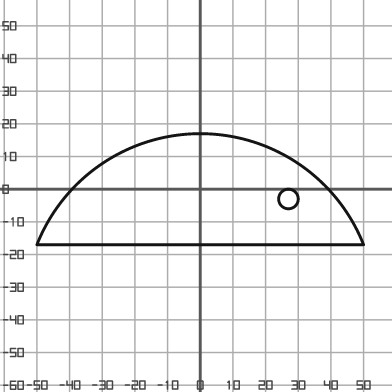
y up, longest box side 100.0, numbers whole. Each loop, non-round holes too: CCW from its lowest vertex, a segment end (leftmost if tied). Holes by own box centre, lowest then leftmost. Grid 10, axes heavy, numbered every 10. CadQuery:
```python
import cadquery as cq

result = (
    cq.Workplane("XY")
    .moveTo(-50.0, -17.0)
    .lineTo(50.0, -17.0)
    .threePointArc((0.0, 17.0), (-50.0, -17.0))
    .close()
    .moveTo(27.0, -3.0)
    .circle(3.0)
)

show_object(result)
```